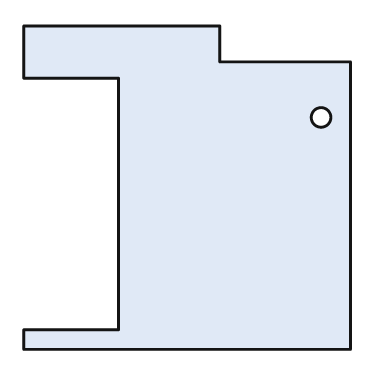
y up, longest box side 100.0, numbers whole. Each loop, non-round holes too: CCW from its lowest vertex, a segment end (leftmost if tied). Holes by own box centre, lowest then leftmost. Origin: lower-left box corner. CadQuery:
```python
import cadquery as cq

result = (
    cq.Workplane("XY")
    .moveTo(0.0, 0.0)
    .lineTo(100.0, 0.0)
    .lineTo(100.0, 88.0)
    .lineTo(60.0, 88.0)
    .lineTo(60.0, 99.0)
    .lineTo(0.0, 99.0)
    .lineTo(0.0, 83.0)
    .lineTo(29.0, 83.0)
    .lineTo(29.0, 6.0)
    .lineTo(0.0, 6.0)
    .close()
    .moveTo(91.0, 71.0)
    .circle(3.0)
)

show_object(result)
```